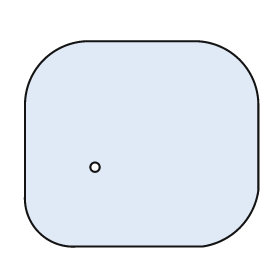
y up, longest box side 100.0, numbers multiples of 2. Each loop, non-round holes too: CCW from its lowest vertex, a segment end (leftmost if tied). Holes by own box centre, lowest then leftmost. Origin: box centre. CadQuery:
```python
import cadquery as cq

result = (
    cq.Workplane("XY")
    .moveTo(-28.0, -44.0)
    .lineTo(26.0, -44.0)
    .threePointArc((42.0, -36.0), (50.0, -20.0))
    .lineTo(50.0, 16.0)
    .threePointArc((42.0, 36.0), (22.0, 44.0))
    .lineTo(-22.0, 44.0)
    .threePointArc((-42.0, 36.0), (-50.0, 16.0))
    .lineTo(-50.0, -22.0)
    .threePointArc((-44.0, -38.0), (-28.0, -44.0))
    .close()
    .moveTo(-20.0, -10.0)
    .circle(2.0)
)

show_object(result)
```